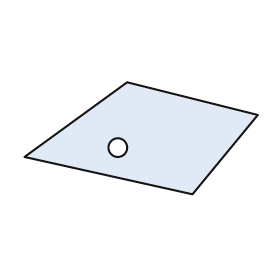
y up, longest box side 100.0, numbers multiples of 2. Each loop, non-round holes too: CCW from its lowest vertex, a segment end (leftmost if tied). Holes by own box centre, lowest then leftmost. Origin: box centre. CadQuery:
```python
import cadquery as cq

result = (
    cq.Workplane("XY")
    .moveTo(22.0, -24.0)
    .lineTo(50.0, 10.0)
    .lineTo(-6.0, 24.0)
    .lineTo(-50.0, -8.0)
    .close()
    .moveTo(-10.0, -4.0)
    .circle(4.0)
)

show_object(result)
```